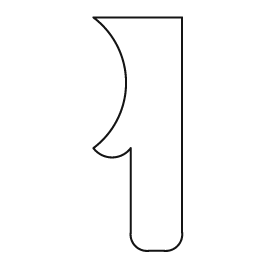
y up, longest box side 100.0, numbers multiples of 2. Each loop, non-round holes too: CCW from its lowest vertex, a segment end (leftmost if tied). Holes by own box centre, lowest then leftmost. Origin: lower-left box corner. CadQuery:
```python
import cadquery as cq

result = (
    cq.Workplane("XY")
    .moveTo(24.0, 0.0)
    .lineTo(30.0, 0.0)
    .threePointArc((36.0, 2.0), (38.0, 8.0))
    .lineTo(38.0, 100.0)
    .lineTo(0.0, 100.0)
    .threePointArc((14.0, 72.0), (0.0, 44.0))
    .threePointArc((8.0, 40.0), (16.0, 44.0))
    .lineTo(16.0, 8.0)
    .threePointArc((18.0, 2.0), (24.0, 0.0))
    .close()
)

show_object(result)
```